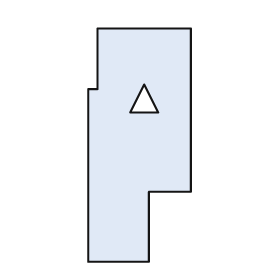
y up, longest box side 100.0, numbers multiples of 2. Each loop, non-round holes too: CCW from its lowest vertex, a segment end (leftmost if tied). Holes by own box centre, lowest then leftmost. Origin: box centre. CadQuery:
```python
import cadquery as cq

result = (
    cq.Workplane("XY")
    .moveTo(-22.0, -50.0)
    .lineTo(4.0, -50.0)
    .lineTo(4.0, -20.0)
    .lineTo(22.0, -20.0)
    .lineTo(22.0, 50.0)
    .lineTo(-18.0, 50.0)
    .lineTo(-18.0, 24.0)
    .lineTo(-22.0, 24.0)
    .close()
    .moveTo(-4.0, 14.0)
    .lineTo(8.0, 14.0)
    .lineTo(2.0, 26.0)
    .close()
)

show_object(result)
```